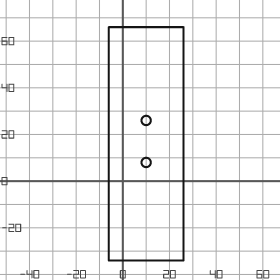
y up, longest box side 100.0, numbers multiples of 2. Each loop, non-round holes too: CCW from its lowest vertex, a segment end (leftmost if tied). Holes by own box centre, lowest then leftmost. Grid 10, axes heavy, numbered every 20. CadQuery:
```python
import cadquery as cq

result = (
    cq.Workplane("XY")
    .moveTo(-6.0, -34.0)
    .lineTo(26.0, -34.0)
    .lineTo(26.0, 66.0)
    .lineTo(-6.0, 66.0)
    .close()
    .moveTo(10.0, 8.0)
    .circle(2.0)
    .moveTo(10.0, 26.0)
    .circle(2.0)
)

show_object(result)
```